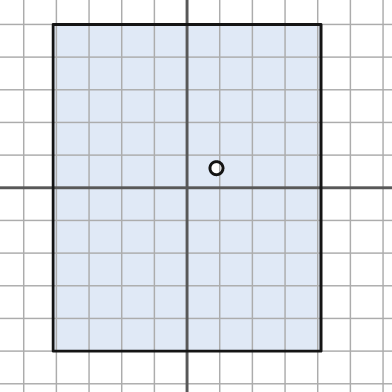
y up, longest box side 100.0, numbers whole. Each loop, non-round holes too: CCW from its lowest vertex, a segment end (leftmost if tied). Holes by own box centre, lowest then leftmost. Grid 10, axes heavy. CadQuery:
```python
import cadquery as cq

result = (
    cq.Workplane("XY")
    .moveTo(-41.0, -50.0)
    .lineTo(41.0, -50.0)
    .lineTo(41.0, 50.0)
    .lineTo(-41.0, 50.0)
    .close()
    .moveTo(9.0, 6.0)
    .circle(2.0)
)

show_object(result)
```